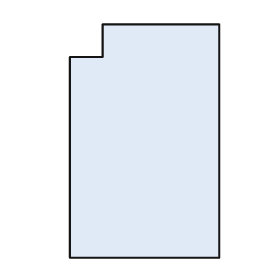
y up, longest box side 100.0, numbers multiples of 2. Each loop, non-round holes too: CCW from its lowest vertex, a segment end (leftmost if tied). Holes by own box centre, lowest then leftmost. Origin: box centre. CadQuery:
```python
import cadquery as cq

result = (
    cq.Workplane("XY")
    .moveTo(-32.0, -50.0)
    .lineTo(32.0, -50.0)
    .lineTo(32.0, 50.0)
    .lineTo(-18.0, 50.0)
    .lineTo(-18.0, 36.0)
    .lineTo(-32.0, 36.0)
    .close()
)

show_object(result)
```